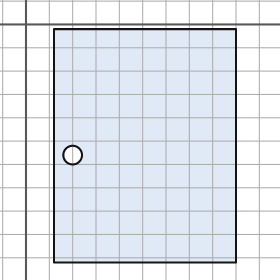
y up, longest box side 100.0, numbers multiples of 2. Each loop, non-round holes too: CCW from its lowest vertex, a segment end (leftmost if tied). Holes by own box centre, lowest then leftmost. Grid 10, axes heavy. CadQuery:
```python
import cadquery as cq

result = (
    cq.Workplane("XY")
    .moveTo(12.0, -102.0)
    .lineTo(90.0, -102.0)
    .lineTo(90.0, -2.0)
    .lineTo(12.0, -2.0)
    .close()
    .moveTo(20.0, -56.0)
    .circle(4.0)
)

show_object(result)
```